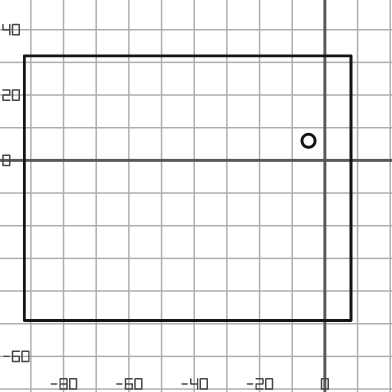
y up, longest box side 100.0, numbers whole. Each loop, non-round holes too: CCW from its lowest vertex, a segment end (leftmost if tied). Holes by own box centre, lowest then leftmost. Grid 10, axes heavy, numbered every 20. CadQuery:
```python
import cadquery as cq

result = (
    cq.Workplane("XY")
    .moveTo(-92.0, -49.0)
    .lineTo(8.0, -49.0)
    .lineTo(8.0, 32.0)
    .lineTo(-92.0, 32.0)
    .close()
    .moveTo(-5.0, 6.0)
    .circle(2.0)
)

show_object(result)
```